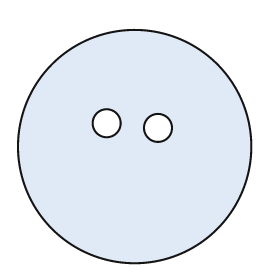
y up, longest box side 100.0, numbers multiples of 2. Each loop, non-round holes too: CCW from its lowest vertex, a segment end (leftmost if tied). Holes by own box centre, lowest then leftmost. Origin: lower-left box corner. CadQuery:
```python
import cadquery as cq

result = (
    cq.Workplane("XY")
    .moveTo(50.0, 50.0)
    .circle(50.0)
    .moveTo(60.0, 58.0)
    .circle(6.0)
    .moveTo(38.0, 60.0)
    .circle(6.0)
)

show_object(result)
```